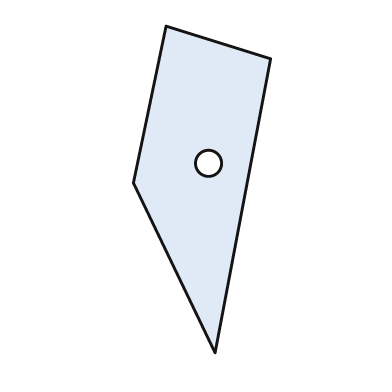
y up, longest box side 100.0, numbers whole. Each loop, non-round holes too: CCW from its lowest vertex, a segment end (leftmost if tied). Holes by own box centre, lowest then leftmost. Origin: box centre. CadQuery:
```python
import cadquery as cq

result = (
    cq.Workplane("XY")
    .moveTo(4.0, -50.0)
    .lineTo(21.0, 40.0)
    .lineTo(-11.0, 50.0)
    .lineTo(-21.0, 2.0)
    .close()
    .moveTo(2.0, 8.0)
    .circle(4.0)
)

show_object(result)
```